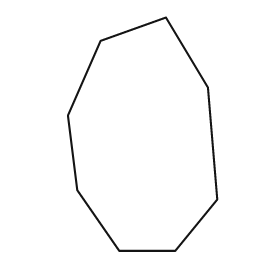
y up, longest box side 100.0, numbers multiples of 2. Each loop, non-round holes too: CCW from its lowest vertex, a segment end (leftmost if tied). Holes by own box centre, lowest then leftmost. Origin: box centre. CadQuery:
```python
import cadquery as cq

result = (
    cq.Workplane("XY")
    .moveTo(-10.0, -50.0)
    .lineTo(14.0, -50.0)
    .lineTo(32.0, -28.0)
    .lineTo(28.0, 20.0)
    .lineTo(10.0, 50.0)
    .lineTo(-18.0, 40.0)
    .lineTo(-32.0, 8.0)
    .lineTo(-28.0, -24.0)
    .close()
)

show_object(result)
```